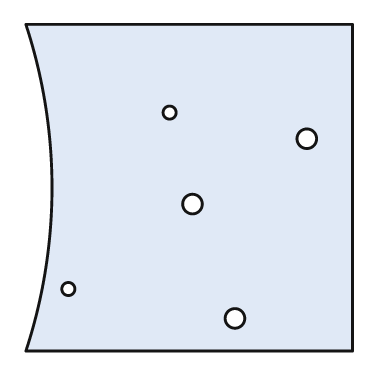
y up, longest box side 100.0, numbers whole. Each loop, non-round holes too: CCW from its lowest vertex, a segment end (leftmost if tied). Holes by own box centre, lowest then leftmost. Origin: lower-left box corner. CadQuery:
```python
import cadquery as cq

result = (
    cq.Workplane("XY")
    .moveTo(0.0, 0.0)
    .lineTo(100.0, 0.0)
    .lineTo(100.0, 100.0)
    .lineTo(0.0, 100.0)
    .threePointArc((8.0, 50.0), (0.0, 0.0))
    .close()
    .moveTo(64.0, 10.0)
    .circle(3.0)
    .moveTo(13.0, 19.0)
    .circle(2.0)
    .moveTo(51.0, 45.0)
    .circle(3.0)
    .moveTo(86.0, 65.0)
    .circle(3.0)
    .moveTo(44.0, 73.0)
    .circle(2.0)
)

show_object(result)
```